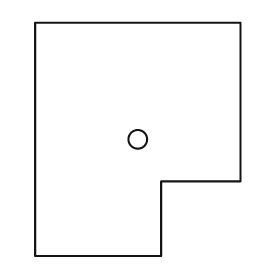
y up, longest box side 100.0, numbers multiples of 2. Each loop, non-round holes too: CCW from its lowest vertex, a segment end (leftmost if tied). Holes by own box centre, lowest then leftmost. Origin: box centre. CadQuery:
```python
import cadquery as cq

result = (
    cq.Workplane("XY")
    .moveTo(-44.0, -50.0)
    .lineTo(10.0, -50.0)
    .lineTo(10.0, -18.0)
    .lineTo(44.0, -18.0)
    .lineTo(44.0, 50.0)
    .lineTo(-44.0, 50.0)
    .close()
    .moveTo(0.0, 0.0)
    .circle(4.0)
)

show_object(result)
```